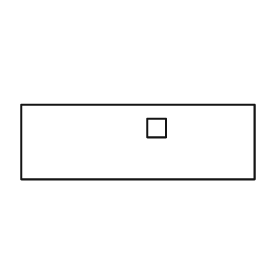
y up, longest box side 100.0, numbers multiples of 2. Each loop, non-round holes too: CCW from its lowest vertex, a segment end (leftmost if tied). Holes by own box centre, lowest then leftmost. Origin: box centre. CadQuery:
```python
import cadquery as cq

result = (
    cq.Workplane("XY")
    .moveTo(-50.0, -16.0)
    .lineTo(50.0, -16.0)
    .lineTo(50.0, 16.0)
    .lineTo(-50.0, 16.0)
    .close()
    .moveTo(4.0, 2.0)
    .lineTo(12.0, 2.0)
    .lineTo(12.0, 10.0)
    .lineTo(4.0, 10.0)
    .close()
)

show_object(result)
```